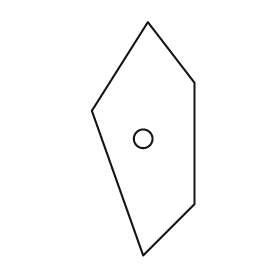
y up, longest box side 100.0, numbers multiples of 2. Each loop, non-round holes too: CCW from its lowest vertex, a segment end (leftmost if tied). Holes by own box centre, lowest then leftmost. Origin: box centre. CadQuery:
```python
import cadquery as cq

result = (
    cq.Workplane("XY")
    .moveTo(0.0, -50.0)
    .lineTo(22.0, -28.0)
    .lineTo(22.0, 24.0)
    .lineTo(2.0, 50.0)
    .lineTo(-22.0, 12.0)
    .close()
    .moveTo(0.0, 0.0)
    .circle(4.0)
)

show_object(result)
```